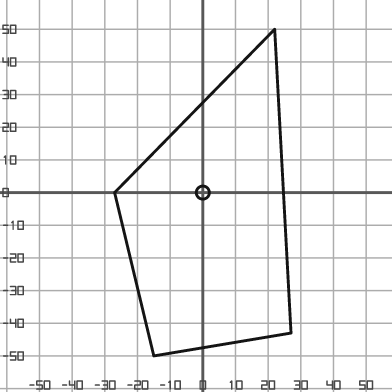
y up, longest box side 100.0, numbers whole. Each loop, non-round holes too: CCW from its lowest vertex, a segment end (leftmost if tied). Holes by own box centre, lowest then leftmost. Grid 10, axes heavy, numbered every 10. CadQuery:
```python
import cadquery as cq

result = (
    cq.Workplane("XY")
    .moveTo(-15.0, -50.0)
    .lineTo(27.0, -43.0)
    .lineTo(22.0, 50.0)
    .lineTo(-27.0, 0.0)
    .close()
    .moveTo(0.0, 0.0)
    .circle(2.0)
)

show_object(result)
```